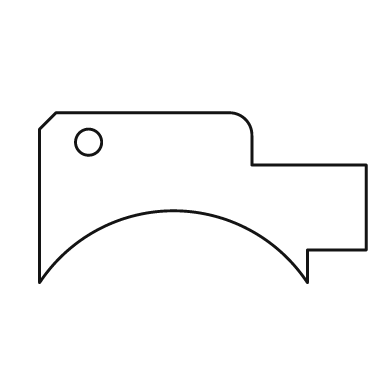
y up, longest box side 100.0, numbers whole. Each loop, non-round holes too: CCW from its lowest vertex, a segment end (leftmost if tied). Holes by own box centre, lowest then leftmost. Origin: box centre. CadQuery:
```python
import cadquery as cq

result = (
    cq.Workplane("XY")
    .moveTo(-50.0, -26.0)
    .threePointArc((-9.0, -4.0), (32.0, -26.0))
    .lineTo(32.0, -16.0)
    .lineTo(50.0, -16.0)
    .lineTo(50.0, 10.0)
    .lineTo(15.0, 10.0)
    .lineTo(15.0, 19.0)
    .threePointArc((13.0, 24.0), (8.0, 26.0))
    .lineTo(-45.0, 26.0)
    .lineTo(-50.0, 21.0)
    .close()
    .moveTo(-35.0, 17.0)
    .circle(4.0)
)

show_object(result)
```